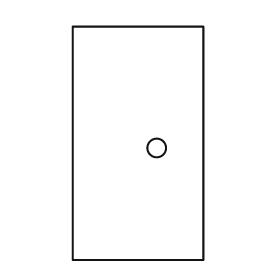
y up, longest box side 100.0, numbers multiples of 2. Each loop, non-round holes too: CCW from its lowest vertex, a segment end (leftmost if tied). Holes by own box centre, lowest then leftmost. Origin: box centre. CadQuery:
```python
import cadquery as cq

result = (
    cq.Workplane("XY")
    .moveTo(-28.0, -50.0)
    .lineTo(28.0, -50.0)
    .lineTo(28.0, 50.0)
    .lineTo(-28.0, 50.0)
    .close()
    .moveTo(8.0, -2.0)
    .circle(4.0)
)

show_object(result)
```